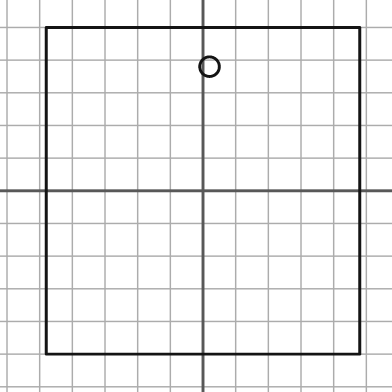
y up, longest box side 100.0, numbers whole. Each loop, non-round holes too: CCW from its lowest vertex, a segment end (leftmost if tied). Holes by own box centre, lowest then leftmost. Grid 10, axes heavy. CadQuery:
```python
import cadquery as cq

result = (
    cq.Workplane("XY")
    .moveTo(-48.0, -50.0)
    .lineTo(48.0, -50.0)
    .lineTo(48.0, 50.0)
    .lineTo(-48.0, 50.0)
    .close()
    .moveTo(2.0, 38.0)
    .circle(3.0)
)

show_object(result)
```